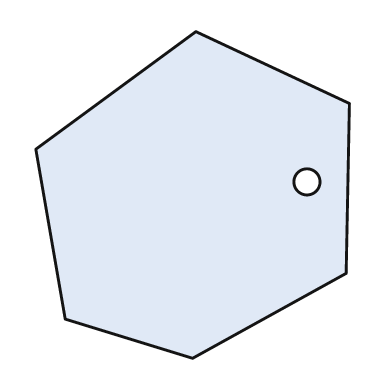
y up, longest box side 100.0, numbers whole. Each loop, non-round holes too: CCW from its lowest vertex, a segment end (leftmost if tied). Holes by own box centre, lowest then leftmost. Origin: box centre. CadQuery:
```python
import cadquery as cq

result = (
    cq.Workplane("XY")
    .moveTo(0.0, -50.0)
    .lineTo(47.0, -24.0)
    .lineTo(48.0, 28.0)
    .lineTo(1.0, 50.0)
    .lineTo(-48.0, 14.0)
    .lineTo(-39.0, -38.0)
    .close()
    .moveTo(35.0, 4.0)
    .circle(4.0)
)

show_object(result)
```